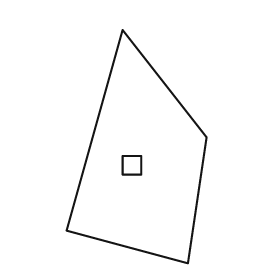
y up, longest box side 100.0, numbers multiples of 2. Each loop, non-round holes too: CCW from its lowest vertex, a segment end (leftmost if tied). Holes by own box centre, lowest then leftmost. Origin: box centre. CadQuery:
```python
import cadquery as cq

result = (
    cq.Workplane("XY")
    .moveTo(22.0, -50.0)
    .lineTo(30.0, 4.0)
    .lineTo(-6.0, 50.0)
    .lineTo(-30.0, -36.0)
    .close()
    .moveTo(-6.0, -12.0)
    .lineTo(2.0, -12.0)
    .lineTo(2.0, -4.0)
    .lineTo(-6.0, -4.0)
    .close()
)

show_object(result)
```